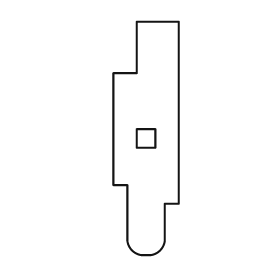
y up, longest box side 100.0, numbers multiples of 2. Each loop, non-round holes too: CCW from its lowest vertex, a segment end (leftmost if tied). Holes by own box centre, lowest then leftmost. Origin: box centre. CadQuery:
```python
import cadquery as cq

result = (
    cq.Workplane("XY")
    .moveTo(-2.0, -50.0)
    .lineTo(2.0, -50.0)
    .threePointArc((6.0, -48.0), (8.0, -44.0))
    .lineTo(8.0, -28.0)
    .lineTo(14.0, -28.0)
    .lineTo(14.0, 50.0)
    .lineTo(-4.0, 50.0)
    .lineTo(-4.0, 28.0)
    .lineTo(-14.0, 28.0)
    .lineTo(-14.0, -20.0)
    .lineTo(-8.0, -20.0)
    .lineTo(-8.0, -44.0)
    .threePointArc((-6.0, -48.0), (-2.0, -50.0))
    .close()
    .moveTo(-4.0, -4.0)
    .lineTo(4.0, -4.0)
    .lineTo(4.0, 4.0)
    .lineTo(-4.0, 4.0)
    .close()
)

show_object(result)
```